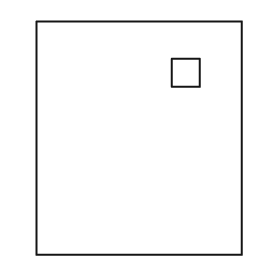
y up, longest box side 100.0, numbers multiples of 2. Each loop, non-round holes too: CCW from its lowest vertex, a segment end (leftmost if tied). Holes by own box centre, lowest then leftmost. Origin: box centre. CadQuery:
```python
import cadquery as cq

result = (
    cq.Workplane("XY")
    .moveTo(-44.0, -50.0)
    .lineTo(44.0, -50.0)
    .lineTo(44.0, 50.0)
    .lineTo(-44.0, 50.0)
    .close()
    .moveTo(14.0, 22.0)
    .lineTo(26.0, 22.0)
    .lineTo(26.0, 34.0)
    .lineTo(14.0, 34.0)
    .close()
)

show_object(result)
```